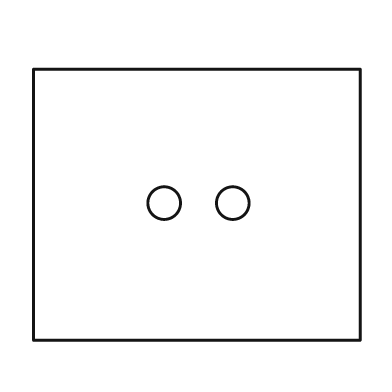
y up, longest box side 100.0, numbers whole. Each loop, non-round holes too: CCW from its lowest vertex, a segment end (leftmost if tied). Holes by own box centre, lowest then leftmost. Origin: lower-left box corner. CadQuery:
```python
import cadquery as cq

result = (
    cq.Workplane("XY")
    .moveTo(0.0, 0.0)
    .lineTo(100.0, 0.0)
    .lineTo(100.0, 83.0)
    .lineTo(0.0, 83.0)
    .close()
    .moveTo(40.0, 42.0)
    .circle(5.0)
    .moveTo(61.0, 42.0)
    .circle(5.0)
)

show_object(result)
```